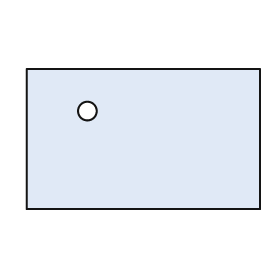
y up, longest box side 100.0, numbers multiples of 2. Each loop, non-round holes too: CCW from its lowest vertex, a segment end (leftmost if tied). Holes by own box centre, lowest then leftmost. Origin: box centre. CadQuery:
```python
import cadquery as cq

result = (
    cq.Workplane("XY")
    .moveTo(-50.0, -30.0)
    .lineTo(50.0, -30.0)
    .lineTo(50.0, 30.0)
    .lineTo(-50.0, 30.0)
    .close()
    .moveTo(-24.0, 12.0)
    .circle(4.0)
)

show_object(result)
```